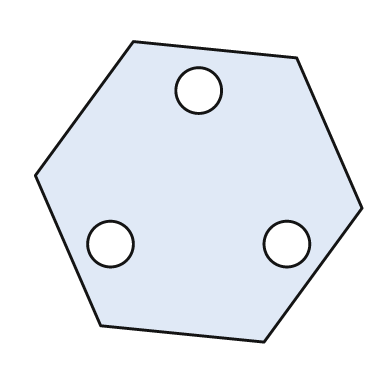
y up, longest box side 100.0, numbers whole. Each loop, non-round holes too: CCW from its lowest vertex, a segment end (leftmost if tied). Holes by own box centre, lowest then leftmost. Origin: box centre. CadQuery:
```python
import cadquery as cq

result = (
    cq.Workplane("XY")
    .moveTo(20.0, -46.0)
    .lineTo(50.0, -5.0)
    .lineTo(30.0, 41.0)
    .lineTo(-20.0, 46.0)
    .lineTo(-50.0, 5.0)
    .lineTo(-30.0, -41.0)
    .close()
    .moveTo(-27.0, -16.0)
    .circle(7.0)
    .moveTo(27.0, -16.0)
    .circle(7.0)
    .moveTo(0.0, 31.0)
    .circle(7.0)
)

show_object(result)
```